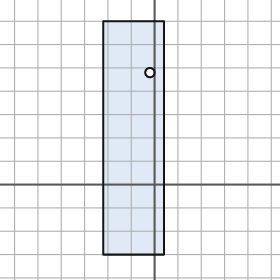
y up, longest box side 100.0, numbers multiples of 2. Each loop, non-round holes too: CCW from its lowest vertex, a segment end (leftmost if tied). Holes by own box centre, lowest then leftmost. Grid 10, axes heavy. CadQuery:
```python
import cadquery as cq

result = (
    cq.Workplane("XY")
    .moveTo(-22.0, -30.0)
    .lineTo(4.0, -30.0)
    .lineTo(4.0, 70.0)
    .lineTo(-22.0, 70.0)
    .close()
    .moveTo(-2.0, 48.0)
    .circle(2.0)
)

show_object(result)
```